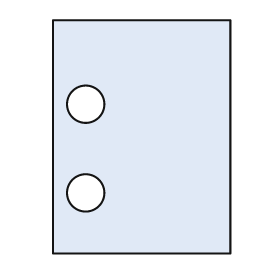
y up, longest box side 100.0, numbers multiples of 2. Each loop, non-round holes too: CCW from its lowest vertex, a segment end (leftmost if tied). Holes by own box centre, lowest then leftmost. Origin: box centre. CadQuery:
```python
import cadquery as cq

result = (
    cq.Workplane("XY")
    .moveTo(-38.0, -50.0)
    .lineTo(38.0, -50.0)
    .lineTo(38.0, 50.0)
    .lineTo(-38.0, 50.0)
    .close()
    .moveTo(-24.0, -24.0)
    .circle(8.0)
    .moveTo(-24.0, 14.0)
    .circle(8.0)
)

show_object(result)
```